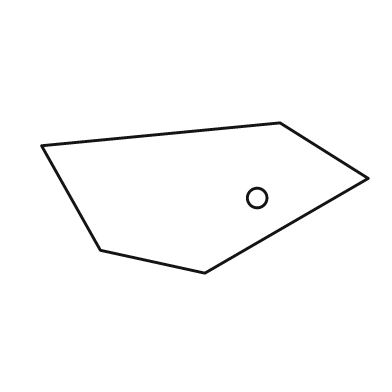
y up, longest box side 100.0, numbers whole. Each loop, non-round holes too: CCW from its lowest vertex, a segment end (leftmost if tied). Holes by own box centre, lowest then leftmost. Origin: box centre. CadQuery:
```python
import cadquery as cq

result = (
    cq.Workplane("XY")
    .moveTo(0.0, -23.0)
    .lineTo(50.0, 6.0)
    .lineTo(23.0, 23.0)
    .lineTo(-50.0, 16.0)
    .lineTo(-32.0, -16.0)
    .close()
    .moveTo(16.0, 0.0)
    .circle(3.0)
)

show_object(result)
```